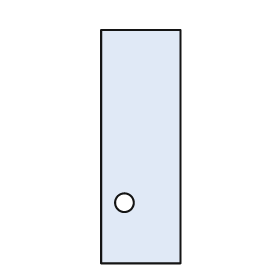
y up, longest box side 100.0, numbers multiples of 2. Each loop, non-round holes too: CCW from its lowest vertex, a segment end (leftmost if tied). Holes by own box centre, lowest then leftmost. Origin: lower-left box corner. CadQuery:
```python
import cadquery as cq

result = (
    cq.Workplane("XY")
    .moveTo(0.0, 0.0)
    .lineTo(34.0, 0.0)
    .lineTo(34.0, 100.0)
    .lineTo(0.0, 100.0)
    .close()
    .moveTo(10.0, 26.0)
    .circle(4.0)
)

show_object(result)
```